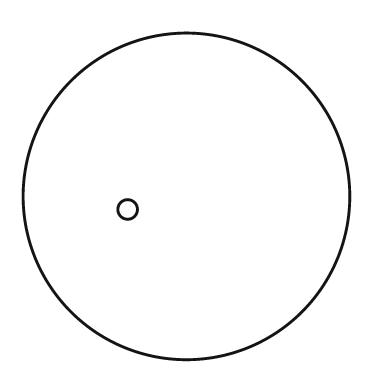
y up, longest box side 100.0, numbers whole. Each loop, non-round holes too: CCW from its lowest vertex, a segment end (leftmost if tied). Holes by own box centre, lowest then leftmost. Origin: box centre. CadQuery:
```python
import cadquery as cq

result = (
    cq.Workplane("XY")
    .moveTo(0.0, 0.0)
    .circle(50.0)
    .moveTo(-18.0, -4.0)
    .circle(3.0)
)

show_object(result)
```